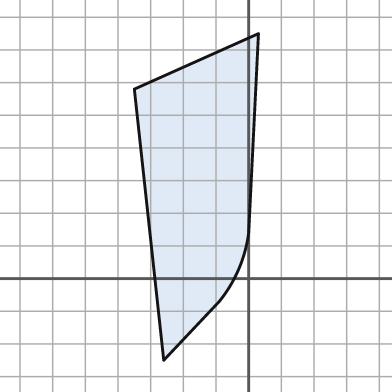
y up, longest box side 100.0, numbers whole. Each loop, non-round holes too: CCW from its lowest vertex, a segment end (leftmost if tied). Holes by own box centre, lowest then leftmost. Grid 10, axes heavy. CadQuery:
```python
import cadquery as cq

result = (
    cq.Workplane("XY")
    .moveTo(-26.0, -25.0)
    .lineTo(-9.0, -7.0)
    .threePointArc((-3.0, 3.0), (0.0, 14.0))
    .lineTo(3.0, 75.0)
    .lineTo(-35.0, 58.0)
    .close()
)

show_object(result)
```